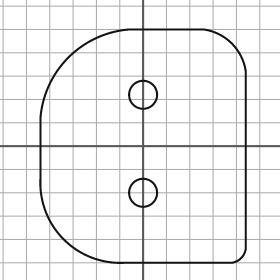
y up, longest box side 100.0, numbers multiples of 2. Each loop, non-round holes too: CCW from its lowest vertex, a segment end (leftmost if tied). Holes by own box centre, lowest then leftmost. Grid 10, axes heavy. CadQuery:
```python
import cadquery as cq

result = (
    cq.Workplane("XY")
    .moveTo(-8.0, -50.0)
    .lineTo(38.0, -50.0)
    .threePointArc((42.0, -48.0), (44.0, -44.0))
    .lineTo(44.0, 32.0)
    .threePointArc((38.0, 44.0), (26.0, 50.0))
    .lineTo(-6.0, 50.0)
    .threePointArc((-32.0, 38.0), (-44.0, 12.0))
    .lineTo(-44.0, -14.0)
    .threePointArc((-34.0, -40.0), (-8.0, -50.0))
    .close()
    .moveTo(0.0, -20.0)
    .circle(6.0)
    .moveTo(0.0, 22.0)
    .circle(6.0)
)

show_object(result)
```